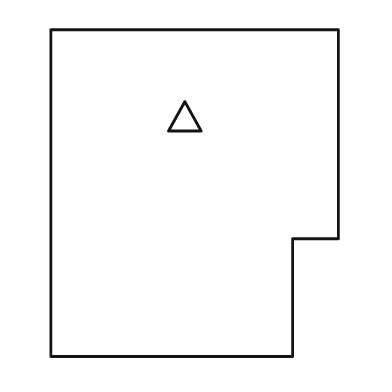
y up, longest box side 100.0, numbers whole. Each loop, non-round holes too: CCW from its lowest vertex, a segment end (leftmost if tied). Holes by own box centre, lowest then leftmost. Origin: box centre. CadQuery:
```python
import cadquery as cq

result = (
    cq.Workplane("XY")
    .moveTo(-44.0, -50.0)
    .lineTo(30.0, -50.0)
    .lineTo(30.0, -14.0)
    .lineTo(44.0, -14.0)
    .lineTo(44.0, 50.0)
    .lineTo(-44.0, 50.0)
    .close()
    .moveTo(-8.0, 19.0)
    .lineTo(2.0, 19.0)
    .lineTo(-3.0, 28.0)
    .close()
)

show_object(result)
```